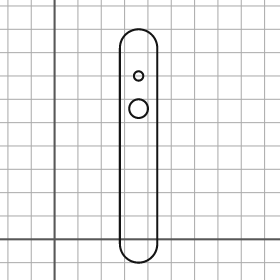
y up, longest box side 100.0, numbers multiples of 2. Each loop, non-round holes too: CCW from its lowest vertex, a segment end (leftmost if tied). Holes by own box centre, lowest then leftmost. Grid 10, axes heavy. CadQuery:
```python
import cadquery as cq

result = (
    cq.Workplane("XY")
    .moveTo(28.0, -2.0)
    .threePointArc((36.0, -10.0), (44.0, -2.0))
    .lineTo(44.0, 82.0)
    .threePointArc((36.0, 90.0), (28.0, 82.0))
    .close()
    .moveTo(36.0, 56.0)
    .circle(4.0)
    .moveTo(36.0, 70.0)
    .circle(2.0)
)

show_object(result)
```